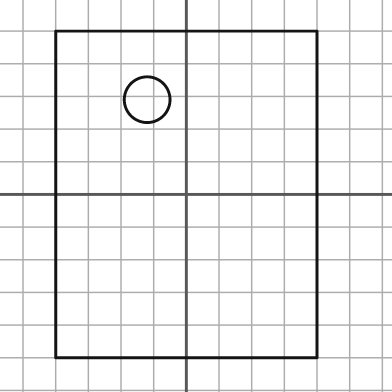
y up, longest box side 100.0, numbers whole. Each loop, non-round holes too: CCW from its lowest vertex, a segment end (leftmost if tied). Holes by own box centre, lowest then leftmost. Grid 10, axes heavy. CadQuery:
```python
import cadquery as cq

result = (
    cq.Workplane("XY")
    .moveTo(-40.0, -50.0)
    .lineTo(40.0, -50.0)
    .lineTo(40.0, 50.0)
    .lineTo(-40.0, 50.0)
    .close()
    .moveTo(-12.0, 29.0)
    .circle(7.0)
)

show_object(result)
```